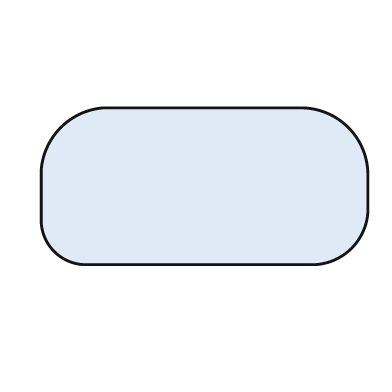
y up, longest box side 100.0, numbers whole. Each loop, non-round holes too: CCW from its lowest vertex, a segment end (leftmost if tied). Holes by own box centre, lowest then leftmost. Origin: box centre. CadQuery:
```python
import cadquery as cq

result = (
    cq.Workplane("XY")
    .moveTo(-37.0, -24.0)
    .lineTo(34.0, -24.0)
    .threePointArc((45.0, -19.0), (50.0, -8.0))
    .lineTo(50.0, 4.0)
    .threePointArc((44.0, 18.0), (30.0, 24.0))
    .lineTo(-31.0, 24.0)
    .threePointArc((-44.0, 18.0), (-50.0, 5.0))
    .lineTo(-50.0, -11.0)
    .threePointArc((-46.0, -20.0), (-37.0, -24.0))
    .close()
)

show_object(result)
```